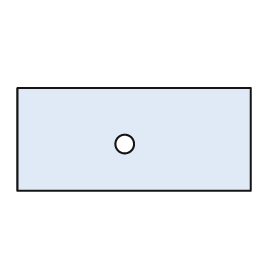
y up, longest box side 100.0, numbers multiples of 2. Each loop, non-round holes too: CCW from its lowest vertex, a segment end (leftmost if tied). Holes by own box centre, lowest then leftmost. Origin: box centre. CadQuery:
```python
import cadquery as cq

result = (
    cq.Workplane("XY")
    .moveTo(-50.0, -22.0)
    .lineTo(50.0, -22.0)
    .lineTo(50.0, 22.0)
    .lineTo(-50.0, 22.0)
    .close()
    .moveTo(-4.0, -2.0)
    .circle(4.0)
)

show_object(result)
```